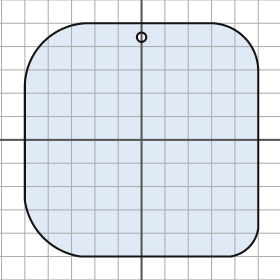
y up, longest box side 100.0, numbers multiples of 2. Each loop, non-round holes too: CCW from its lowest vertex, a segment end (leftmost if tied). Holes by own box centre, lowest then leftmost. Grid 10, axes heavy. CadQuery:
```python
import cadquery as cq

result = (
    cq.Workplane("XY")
    .moveTo(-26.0, -50.0)
    .lineTo(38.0, -50.0)
    .threePointArc((46.0, -46.0), (50.0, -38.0))
    .lineTo(50.0, 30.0)
    .threePointArc((44.0, 44.0), (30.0, 50.0))
    .lineTo(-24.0, 50.0)
    .threePointArc((-42.0, 42.0), (-50.0, 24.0))
    .lineTo(-50.0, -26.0)
    .threePointArc((-42.0, -42.0), (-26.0, -50.0))
    .close()
    .moveTo(0.0, 44.0)
    .circle(2.0)
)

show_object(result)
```